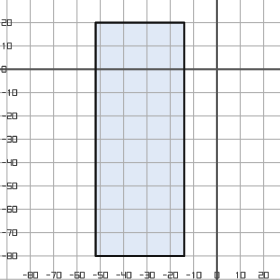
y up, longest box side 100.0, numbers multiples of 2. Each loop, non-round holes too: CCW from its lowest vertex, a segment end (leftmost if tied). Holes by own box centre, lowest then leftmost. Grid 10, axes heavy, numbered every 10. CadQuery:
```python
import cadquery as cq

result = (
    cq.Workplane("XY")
    .moveTo(-52.0, -80.0)
    .lineTo(-14.0, -80.0)
    .lineTo(-14.0, 20.0)
    .lineTo(-52.0, 20.0)
    .close()
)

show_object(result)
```